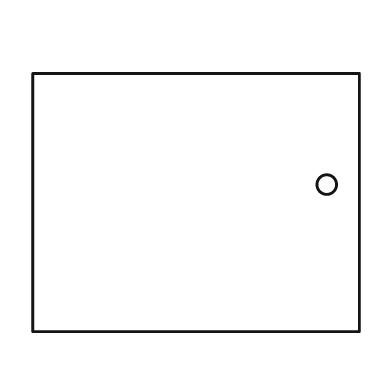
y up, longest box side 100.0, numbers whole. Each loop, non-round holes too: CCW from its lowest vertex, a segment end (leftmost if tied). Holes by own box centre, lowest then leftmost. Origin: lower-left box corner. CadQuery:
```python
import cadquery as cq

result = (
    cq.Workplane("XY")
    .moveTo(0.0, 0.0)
    .lineTo(100.0, 0.0)
    .lineTo(100.0, 79.0)
    .lineTo(0.0, 79.0)
    .close()
    .moveTo(90.0, 45.0)
    .circle(3.0)
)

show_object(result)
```